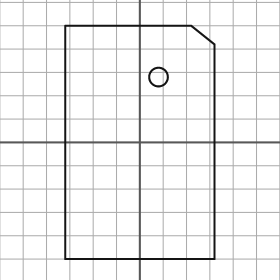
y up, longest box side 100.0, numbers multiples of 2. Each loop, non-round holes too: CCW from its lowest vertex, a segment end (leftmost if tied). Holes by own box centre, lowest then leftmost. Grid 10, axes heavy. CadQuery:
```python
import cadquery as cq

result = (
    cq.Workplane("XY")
    .moveTo(-32.0, -50.0)
    .lineTo(32.0, -50.0)
    .lineTo(32.0, 42.0)
    .lineTo(22.0, 50.0)
    .lineTo(-32.0, 50.0)
    .close()
    .moveTo(8.0, 28.0)
    .circle(4.0)
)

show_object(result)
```